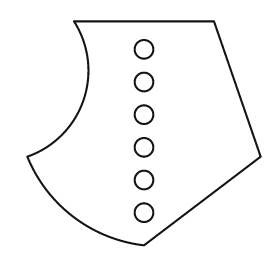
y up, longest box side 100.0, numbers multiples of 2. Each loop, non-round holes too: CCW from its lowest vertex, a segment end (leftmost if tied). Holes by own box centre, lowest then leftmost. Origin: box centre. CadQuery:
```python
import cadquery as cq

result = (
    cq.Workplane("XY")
    .moveTo(0.0, -48.0)
    .lineTo(50.0, -10.0)
    .lineTo(30.0, 48.0)
    .lineTo(-30.0, 48.0)
    .threePointArc((-26.0, 14.0), (-50.0, -10.0))
    .threePointArc((-30.0, -36.0), (0.0, -48.0))
    .close()
    .moveTo(0.0, -34.0)
    .circle(4.0)
    .moveTo(0.0, -20.0)
    .circle(4.0)
    .moveTo(0.0, -6.0)
    .circle(4.0)
    .moveTo(0.0, 8.0)
    .circle(4.0)
    .moveTo(0.0, 22.0)
    .circle(4.0)
    .moveTo(0.0, 36.0)
    .circle(4.0)
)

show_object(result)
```